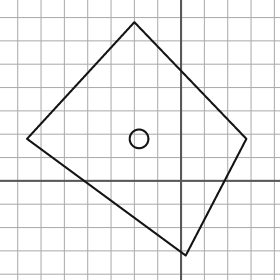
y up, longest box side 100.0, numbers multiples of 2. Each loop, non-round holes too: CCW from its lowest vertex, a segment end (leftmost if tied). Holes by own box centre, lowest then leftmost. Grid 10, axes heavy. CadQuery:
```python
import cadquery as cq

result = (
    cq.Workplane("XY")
    .moveTo(2.0, -32.0)
    .lineTo(28.0, 18.0)
    .lineTo(-20.0, 68.0)
    .lineTo(-66.0, 18.0)
    .close()
    .moveTo(-18.0, 18.0)
    .circle(4.0)
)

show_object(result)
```